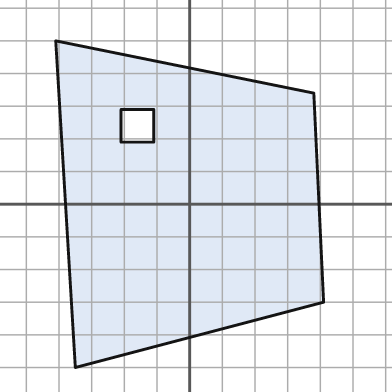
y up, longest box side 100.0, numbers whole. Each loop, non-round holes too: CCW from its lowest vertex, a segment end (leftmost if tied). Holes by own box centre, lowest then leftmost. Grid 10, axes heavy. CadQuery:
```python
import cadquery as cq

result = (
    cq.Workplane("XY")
    .moveTo(-35.0, -50.0)
    .lineTo(41.0, -30.0)
    .lineTo(38.0, 34.0)
    .lineTo(-41.0, 50.0)
    .close()
    .moveTo(-21.0, 19.0)
    .lineTo(-11.0, 19.0)
    .lineTo(-11.0, 29.0)
    .lineTo(-21.0, 29.0)
    .close()
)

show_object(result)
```